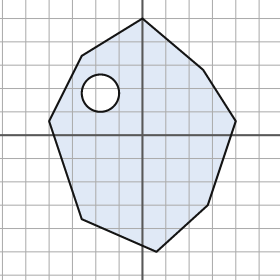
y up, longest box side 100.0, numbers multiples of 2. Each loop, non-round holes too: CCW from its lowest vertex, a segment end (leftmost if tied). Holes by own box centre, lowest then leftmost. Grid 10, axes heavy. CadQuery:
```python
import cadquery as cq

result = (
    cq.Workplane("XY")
    .moveTo(6.0, -50.0)
    .lineTo(28.0, -30.0)
    .lineTo(40.0, 6.0)
    .lineTo(26.0, 28.0)
    .lineTo(0.0, 50.0)
    .lineTo(-26.0, 34.0)
    .lineTo(-40.0, 6.0)
    .lineTo(-26.0, -36.0)
    .close()
    .moveTo(-18.0, 18.0)
    .circle(8.0)
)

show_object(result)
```